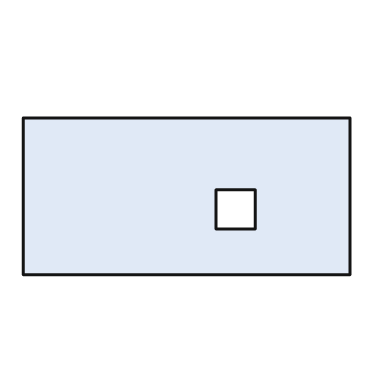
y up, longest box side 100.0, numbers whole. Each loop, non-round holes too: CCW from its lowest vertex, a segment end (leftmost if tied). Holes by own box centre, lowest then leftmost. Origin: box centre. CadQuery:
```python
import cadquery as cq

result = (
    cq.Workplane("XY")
    .moveTo(-50.0, -24.0)
    .lineTo(50.0, -24.0)
    .lineTo(50.0, 24.0)
    .lineTo(-50.0, 24.0)
    .close()
    .moveTo(9.0, -10.0)
    .lineTo(21.0, -10.0)
    .lineTo(21.0, 2.0)
    .lineTo(9.0, 2.0)
    .close()
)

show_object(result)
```